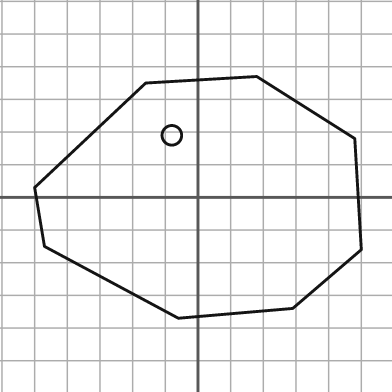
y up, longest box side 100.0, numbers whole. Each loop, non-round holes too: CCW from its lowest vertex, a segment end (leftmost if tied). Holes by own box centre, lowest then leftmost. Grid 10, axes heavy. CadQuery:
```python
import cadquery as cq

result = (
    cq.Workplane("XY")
    .moveTo(-6.0, -37.0)
    .lineTo(29.0, -34.0)
    .lineTo(50.0, -16.0)
    .lineTo(48.0, 18.0)
    .lineTo(18.0, 37.0)
    .lineTo(-16.0, 35.0)
    .lineTo(-50.0, 3.0)
    .lineTo(-47.0, -15.0)
    .close()
    .moveTo(-8.0, 19.0)
    .circle(3.0)
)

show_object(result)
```